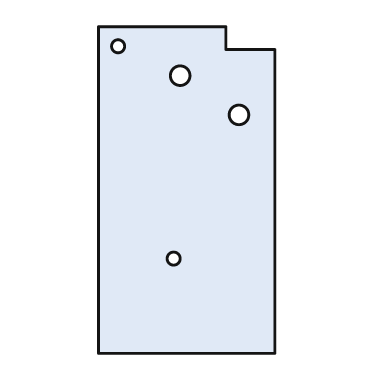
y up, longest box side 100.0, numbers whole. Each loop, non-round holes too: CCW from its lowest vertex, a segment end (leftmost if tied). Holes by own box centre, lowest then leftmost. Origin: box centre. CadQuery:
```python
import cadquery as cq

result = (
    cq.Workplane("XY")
    .moveTo(-27.0, -50.0)
    .lineTo(27.0, -50.0)
    .lineTo(27.0, 43.0)
    .lineTo(12.0, 43.0)
    .lineTo(12.0, 50.0)
    .lineTo(-27.0, 50.0)
    .close()
    .moveTo(-4.0, -21.0)
    .circle(2.0)
    .moveTo(16.0, 23.0)
    .circle(3.0)
    .moveTo(-2.0, 35.0)
    .circle(3.0)
    .moveTo(-21.0, 44.0)
    .circle(2.0)
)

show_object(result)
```